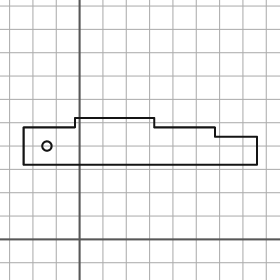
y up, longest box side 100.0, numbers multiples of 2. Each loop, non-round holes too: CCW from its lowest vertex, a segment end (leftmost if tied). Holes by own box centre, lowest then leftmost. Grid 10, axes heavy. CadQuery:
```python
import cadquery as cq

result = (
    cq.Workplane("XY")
    .moveTo(-24.0, 32.0)
    .lineTo(76.0, 32.0)
    .lineTo(76.0, 44.0)
    .lineTo(58.0, 44.0)
    .lineTo(58.0, 48.0)
    .lineTo(32.0, 48.0)
    .lineTo(32.0, 52.0)
    .lineTo(-2.0, 52.0)
    .lineTo(-2.0, 48.0)
    .lineTo(-24.0, 48.0)
    .close()
    .moveTo(-14.0, 40.0)
    .circle(2.0)
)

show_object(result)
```